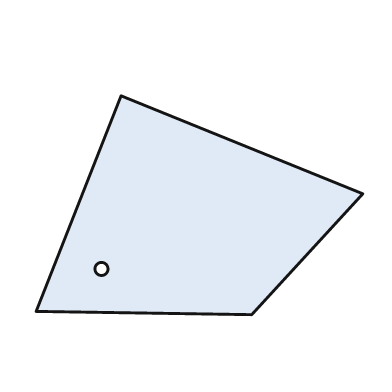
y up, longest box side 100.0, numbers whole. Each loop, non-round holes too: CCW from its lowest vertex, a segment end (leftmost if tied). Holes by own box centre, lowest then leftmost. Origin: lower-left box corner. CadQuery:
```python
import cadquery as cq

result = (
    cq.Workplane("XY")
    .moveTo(66.0, 0.0)
    .lineTo(100.0, 37.0)
    .lineTo(26.0, 67.0)
    .lineTo(0.0, 1.0)
    .close()
    .moveTo(20.0, 14.0)
    .circle(2.0)
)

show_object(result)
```